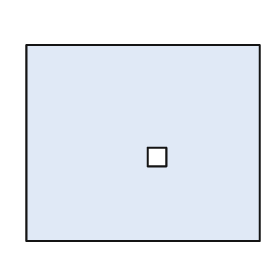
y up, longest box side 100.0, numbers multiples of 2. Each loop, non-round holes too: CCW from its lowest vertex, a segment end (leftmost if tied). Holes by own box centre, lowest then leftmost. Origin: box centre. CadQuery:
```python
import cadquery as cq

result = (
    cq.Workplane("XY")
    .moveTo(-50.0, -42.0)
    .lineTo(50.0, -42.0)
    .lineTo(50.0, 42.0)
    .lineTo(-50.0, 42.0)
    .close()
    .moveTo(2.0, -10.0)
    .lineTo(10.0, -10.0)
    .lineTo(10.0, -2.0)
    .lineTo(2.0, -2.0)
    .close()
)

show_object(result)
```